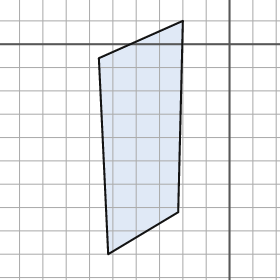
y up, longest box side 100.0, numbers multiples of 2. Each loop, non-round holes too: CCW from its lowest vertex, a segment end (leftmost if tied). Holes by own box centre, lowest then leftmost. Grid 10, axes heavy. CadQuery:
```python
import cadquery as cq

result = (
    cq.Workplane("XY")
    .moveTo(-52.0, -90.0)
    .lineTo(-22.0, -72.0)
    .lineTo(-20.0, 10.0)
    .lineTo(-56.0, -6.0)
    .close()
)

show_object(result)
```